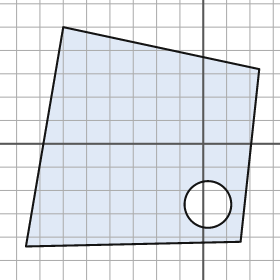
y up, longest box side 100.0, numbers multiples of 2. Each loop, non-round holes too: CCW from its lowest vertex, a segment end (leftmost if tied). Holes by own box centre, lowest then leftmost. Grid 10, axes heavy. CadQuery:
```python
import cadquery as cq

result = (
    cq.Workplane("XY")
    .moveTo(-76.0, -44.0)
    .lineTo(16.0, -42.0)
    .lineTo(24.0, 32.0)
    .lineTo(-60.0, 50.0)
    .close()
    .moveTo(2.0, -26.0)
    .circle(10.0)
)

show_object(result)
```